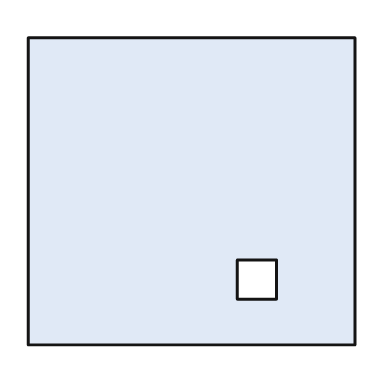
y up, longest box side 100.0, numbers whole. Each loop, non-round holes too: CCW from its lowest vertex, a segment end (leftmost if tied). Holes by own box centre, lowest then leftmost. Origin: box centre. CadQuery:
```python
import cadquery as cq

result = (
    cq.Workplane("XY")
    .moveTo(-50.0, -47.0)
    .lineTo(50.0, -47.0)
    .lineTo(50.0, 47.0)
    .lineTo(-50.0, 47.0)
    .close()
    .moveTo(14.0, -33.0)
    .lineTo(26.0, -33.0)
    .lineTo(26.0, -21.0)
    .lineTo(14.0, -21.0)
    .close()
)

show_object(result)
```